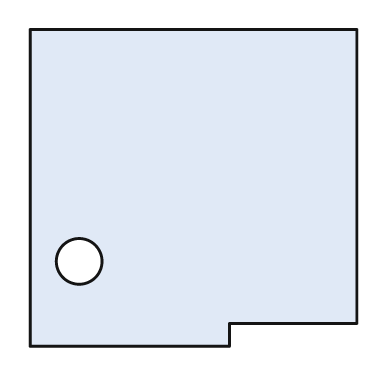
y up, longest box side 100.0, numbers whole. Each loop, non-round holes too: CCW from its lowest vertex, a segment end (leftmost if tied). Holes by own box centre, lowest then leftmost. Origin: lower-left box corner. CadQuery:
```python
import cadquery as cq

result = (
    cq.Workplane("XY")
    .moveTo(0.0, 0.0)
    .lineTo(61.0, 0.0)
    .lineTo(61.0, 7.0)
    .lineTo(100.0, 7.0)
    .lineTo(100.0, 97.0)
    .lineTo(0.0, 97.0)
    .close()
    .moveTo(15.0, 26.0)
    .circle(7.0)
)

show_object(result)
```